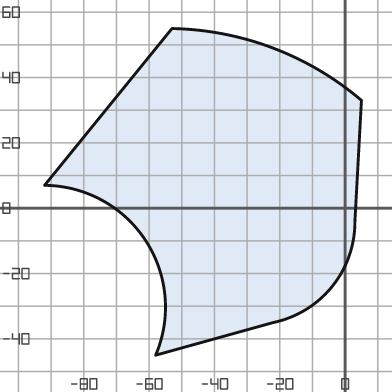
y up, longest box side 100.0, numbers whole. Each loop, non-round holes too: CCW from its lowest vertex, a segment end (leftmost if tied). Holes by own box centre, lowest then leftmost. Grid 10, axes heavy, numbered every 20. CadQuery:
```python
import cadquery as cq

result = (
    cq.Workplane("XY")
    .moveTo(-58.0, -45.0)
    .lineTo(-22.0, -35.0)
    .threePointArc((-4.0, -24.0), (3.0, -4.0))
    .lineTo(5.0, 33.0)
    .threePointArc((-22.0, 49.0), (-53.0, 55.0))
    .lineTo(-92.0, 7.0)
    .threePointArc((-61.0, -10.0), (-58.0, -45.0))
    .close()
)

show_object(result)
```